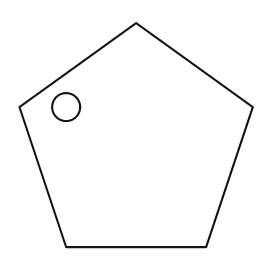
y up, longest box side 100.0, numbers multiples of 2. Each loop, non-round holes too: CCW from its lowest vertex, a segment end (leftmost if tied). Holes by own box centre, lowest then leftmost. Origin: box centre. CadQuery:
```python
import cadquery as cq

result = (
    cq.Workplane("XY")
    .moveTo(-30.0, -48.0)
    .lineTo(30.0, -48.0)
    .lineTo(50.0, 12.0)
    .lineTo(0.0, 48.0)
    .lineTo(-50.0, 12.0)
    .close()
    .moveTo(-30.0, 12.0)
    .circle(6.0)
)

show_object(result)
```